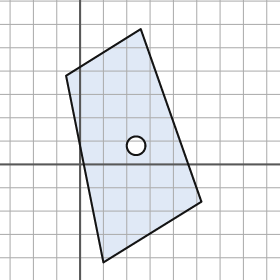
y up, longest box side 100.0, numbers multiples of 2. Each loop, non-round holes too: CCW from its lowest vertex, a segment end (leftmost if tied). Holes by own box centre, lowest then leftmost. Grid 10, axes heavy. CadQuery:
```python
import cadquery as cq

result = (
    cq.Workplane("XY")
    .moveTo(10.0, -42.0)
    .lineTo(52.0, -16.0)
    .lineTo(26.0, 58.0)
    .lineTo(-6.0, 38.0)
    .close()
    .moveTo(24.0, 8.0)
    .circle(4.0)
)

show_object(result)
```